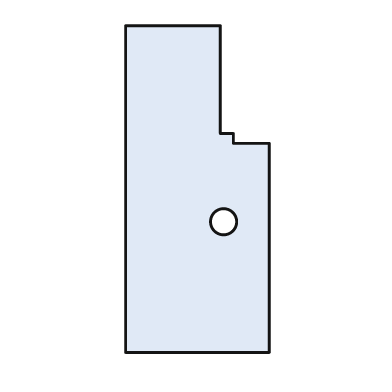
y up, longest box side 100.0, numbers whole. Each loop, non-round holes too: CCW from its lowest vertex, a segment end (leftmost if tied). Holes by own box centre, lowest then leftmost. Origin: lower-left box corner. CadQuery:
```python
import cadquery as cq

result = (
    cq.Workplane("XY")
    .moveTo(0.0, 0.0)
    .lineTo(44.0, 0.0)
    .lineTo(44.0, 64.0)
    .lineTo(33.0, 64.0)
    .lineTo(33.0, 67.0)
    .lineTo(29.0, 67.0)
    .lineTo(29.0, 100.0)
    .lineTo(0.0, 100.0)
    .close()
    .moveTo(30.0, 40.0)
    .circle(4.0)
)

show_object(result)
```